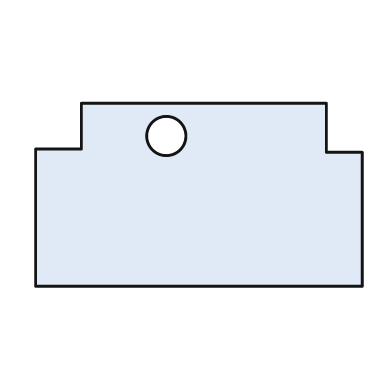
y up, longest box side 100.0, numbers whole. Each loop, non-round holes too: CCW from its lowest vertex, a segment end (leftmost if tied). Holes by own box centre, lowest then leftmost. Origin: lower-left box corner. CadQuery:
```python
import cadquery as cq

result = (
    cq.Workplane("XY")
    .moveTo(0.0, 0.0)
    .lineTo(100.0, 0.0)
    .lineTo(100.0, 41.0)
    .lineTo(89.0, 41.0)
    .lineTo(89.0, 56.0)
    .lineTo(14.0, 56.0)
    .lineTo(14.0, 42.0)
    .lineTo(0.0, 42.0)
    .close()
    .moveTo(40.0, 46.0)
    .circle(6.0)
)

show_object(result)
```